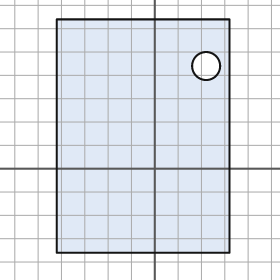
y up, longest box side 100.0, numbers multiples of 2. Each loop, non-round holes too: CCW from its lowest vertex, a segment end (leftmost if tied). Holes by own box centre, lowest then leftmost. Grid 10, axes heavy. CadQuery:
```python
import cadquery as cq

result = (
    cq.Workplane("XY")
    .moveTo(-42.0, -36.0)
    .lineTo(32.0, -36.0)
    .lineTo(32.0, 64.0)
    .lineTo(-42.0, 64.0)
    .close()
    .moveTo(22.0, 44.0)
    .circle(6.0)
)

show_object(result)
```